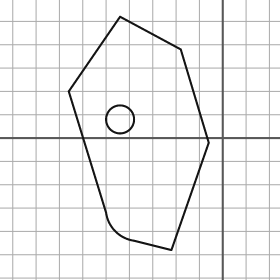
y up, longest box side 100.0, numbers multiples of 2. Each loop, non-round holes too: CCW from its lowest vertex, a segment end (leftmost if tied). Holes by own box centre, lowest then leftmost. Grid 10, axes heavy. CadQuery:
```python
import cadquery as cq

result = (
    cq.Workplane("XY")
    .moveTo(-22.0, -48.0)
    .lineTo(-6.0, -2.0)
    .lineTo(-18.0, 38.0)
    .lineTo(-44.0, 52.0)
    .lineTo(-66.0, 20.0)
    .lineTo(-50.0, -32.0)
    .threePointArc((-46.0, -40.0), (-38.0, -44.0))
    .close()
    .moveTo(-44.0, 8.0)
    .circle(6.0)
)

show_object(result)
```